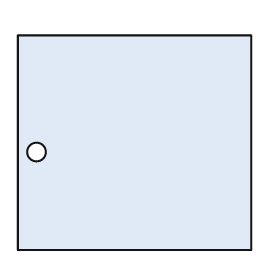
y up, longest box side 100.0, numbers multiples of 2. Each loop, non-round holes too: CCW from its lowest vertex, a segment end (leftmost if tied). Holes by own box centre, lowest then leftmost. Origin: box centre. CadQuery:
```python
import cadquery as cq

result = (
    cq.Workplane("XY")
    .moveTo(-50.0, -46.0)
    .lineTo(50.0, -46.0)
    .lineTo(50.0, 46.0)
    .lineTo(-50.0, 46.0)
    .close()
    .moveTo(-42.0, -4.0)
    .circle(4.0)
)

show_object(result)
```